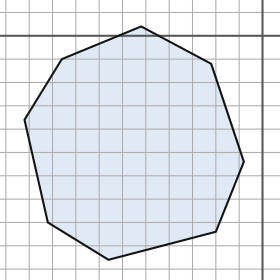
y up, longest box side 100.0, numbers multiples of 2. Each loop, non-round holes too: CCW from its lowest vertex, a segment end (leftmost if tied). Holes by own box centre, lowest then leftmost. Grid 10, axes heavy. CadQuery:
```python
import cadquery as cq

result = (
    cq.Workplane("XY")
    .moveTo(-66.0, -96.0)
    .lineTo(-20.0, -84.0)
    .lineTo(-8.0, -54.0)
    .lineTo(-22.0, -12.0)
    .lineTo(-52.0, 4.0)
    .lineTo(-86.0, -10.0)
    .lineTo(-102.0, -36.0)
    .lineTo(-92.0, -80.0)
    .close()
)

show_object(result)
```